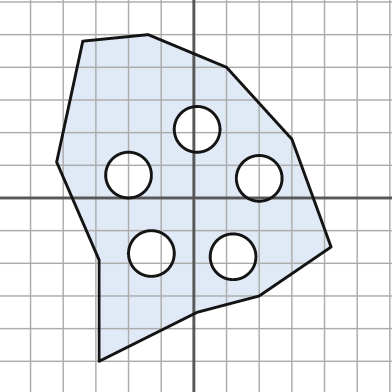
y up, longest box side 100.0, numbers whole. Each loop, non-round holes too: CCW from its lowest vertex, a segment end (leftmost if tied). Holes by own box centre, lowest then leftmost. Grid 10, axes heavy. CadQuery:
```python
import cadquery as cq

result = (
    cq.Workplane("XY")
    .moveTo(-29.0, -50.0)
    .lineTo(1.0, -35.0)
    .lineTo(20.0, -30.0)
    .lineTo(42.0, -15.0)
    .lineTo(30.0, 18.0)
    .lineTo(10.0, 40.0)
    .lineTo(-14.0, 50.0)
    .lineTo(-34.0, 48.0)
    .lineTo(-42.0, 11.0)
    .lineTo(-29.0, -19.0)
    .close()
    .moveTo(12.0, -18.0)
    .circle(7.0)
    .moveTo(-13.0, -17.0)
    .circle(7.0)
    .moveTo(20.0, 6.0)
    .circle(7.0)
    .moveTo(-20.0, 7.0)
    .circle(7.0)
    .moveTo(1.0, 21.0)
    .circle(7.0)
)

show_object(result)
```